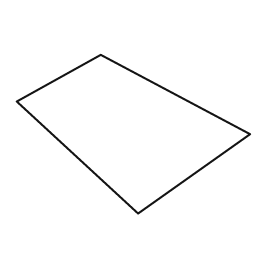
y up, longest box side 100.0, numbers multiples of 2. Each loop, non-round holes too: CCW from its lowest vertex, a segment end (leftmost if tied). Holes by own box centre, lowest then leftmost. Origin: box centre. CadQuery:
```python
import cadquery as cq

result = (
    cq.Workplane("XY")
    .moveTo(2.0, -34.0)
    .lineTo(50.0, 0.0)
    .lineTo(-14.0, 34.0)
    .lineTo(-50.0, 14.0)
    .close()
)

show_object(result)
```